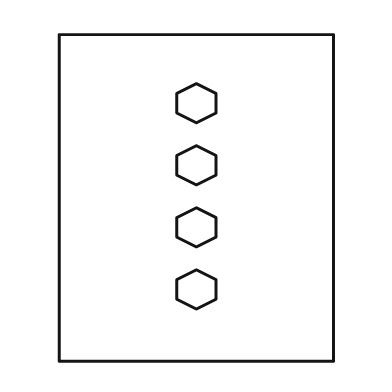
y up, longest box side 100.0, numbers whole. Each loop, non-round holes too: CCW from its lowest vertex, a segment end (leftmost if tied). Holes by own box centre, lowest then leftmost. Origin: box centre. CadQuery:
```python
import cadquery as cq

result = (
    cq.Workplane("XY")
    .moveTo(-42.0, -50.0)
    .lineTo(42.0, -50.0)
    .lineTo(42.0, 50.0)
    .lineTo(-42.0, 50.0)
    .close()
    .moveTo(0.0, -34.0)
    .lineTo(6.0, -31.0)
    .lineTo(6.0, -25.0)
    .lineTo(0.0, -22.0)
    .lineTo(-6.0, -25.0)
    .lineTo(-6.0, -31.0)
    .close()
    .moveTo(0.0, -15.0)
    .lineTo(6.0, -12.0)
    .lineTo(6.0, -6.0)
    .lineTo(0.0, -3.0)
    .lineTo(-6.0, -6.0)
    .lineTo(-6.0, -12.0)
    .close()
    .moveTo(0.0, 4.0)
    .lineTo(6.0, 7.0)
    .lineTo(6.0, 13.0)
    .lineTo(0.0, 16.0)
    .lineTo(-6.0, 13.0)
    .lineTo(-6.0, 7.0)
    .close()
    .moveTo(0.0, 23.0)
    .lineTo(6.0, 26.0)
    .lineTo(6.0, 32.0)
    .lineTo(0.0, 35.0)
    .lineTo(-6.0, 32.0)
    .lineTo(-6.0, 26.0)
    .close()
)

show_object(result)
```